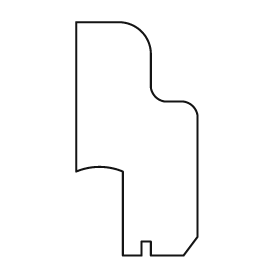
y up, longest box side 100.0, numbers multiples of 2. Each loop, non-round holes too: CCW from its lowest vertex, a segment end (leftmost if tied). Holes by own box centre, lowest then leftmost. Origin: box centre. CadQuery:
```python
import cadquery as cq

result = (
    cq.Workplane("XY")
    .moveTo(-6.0, -50.0)
    .lineTo(2.0, -50.0)
    .lineTo(2.0, -44.0)
    .lineTo(6.0, -44.0)
    .lineTo(6.0, -50.0)
    .lineTo(20.0, -50.0)
    .lineTo(26.0, -42.0)
    .lineTo(26.0, 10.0)
    .threePointArc((24.0, 14.0), (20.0, 16.0))
    .lineTo(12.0, 16.0)
    .threePointArc((8.0, 18.0), (6.0, 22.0))
    .lineTo(6.0, 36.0)
    .threePointArc((2.0, 46.0), (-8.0, 50.0))
    .lineTo(-26.0, 50.0)
    .lineTo(-26.0, -14.0)
    .threePointArc((-16.0, -12.0), (-6.0, -14.0))
    .close()
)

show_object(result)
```